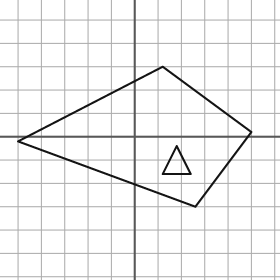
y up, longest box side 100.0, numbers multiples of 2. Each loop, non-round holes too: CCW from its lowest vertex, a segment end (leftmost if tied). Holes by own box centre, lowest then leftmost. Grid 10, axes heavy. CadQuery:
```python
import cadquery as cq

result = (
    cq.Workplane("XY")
    .moveTo(26.0, -30.0)
    .lineTo(50.0, 2.0)
    .lineTo(12.0, 30.0)
    .lineTo(-50.0, -2.0)
    .close()
    .moveTo(12.0, -16.0)
    .lineTo(24.0, -16.0)
    .lineTo(18.0, -4.0)
    .close()
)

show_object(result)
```